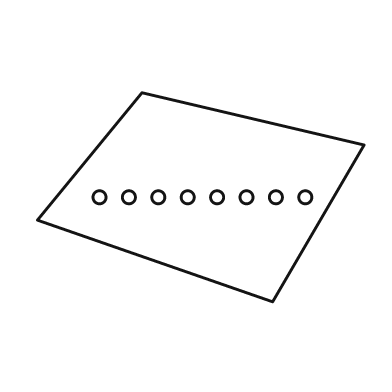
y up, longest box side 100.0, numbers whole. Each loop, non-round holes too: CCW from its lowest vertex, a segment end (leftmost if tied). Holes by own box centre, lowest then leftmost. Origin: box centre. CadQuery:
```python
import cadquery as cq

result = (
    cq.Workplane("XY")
    .moveTo(22.0, -32.0)
    .lineTo(50.0, 16.0)
    .lineTo(-18.0, 32.0)
    .lineTo(-50.0, -7.0)
    .close()
    .moveTo(-31.0, 0.0)
    .circle(2.0)
    .moveTo(-22.0, 0.0)
    .circle(2.0)
    .moveTo(-13.0, 0.0)
    .circle(2.0)
    .moveTo(-4.0, 0.0)
    .circle(2.0)
    .moveTo(5.0, 0.0)
    .circle(2.0)
    .moveTo(14.0, 0.0)
    .circle(2.0)
    .moveTo(23.0, 0.0)
    .circle(2.0)
    .moveTo(32.0, 0.0)
    .circle(2.0)
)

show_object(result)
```